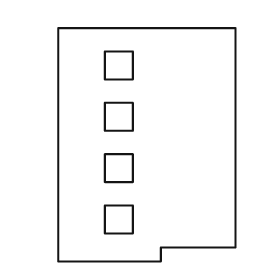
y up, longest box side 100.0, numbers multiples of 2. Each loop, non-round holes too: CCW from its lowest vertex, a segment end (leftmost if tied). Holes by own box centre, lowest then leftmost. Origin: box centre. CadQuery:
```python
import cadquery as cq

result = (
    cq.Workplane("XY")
    .moveTo(-38.0, -50.0)
    .lineTo(6.0, -50.0)
    .lineTo(6.0, -44.0)
    .lineTo(38.0, -44.0)
    .lineTo(38.0, 50.0)
    .lineTo(-38.0, 50.0)
    .close()
    .moveTo(-18.0, -38.0)
    .lineTo(-6.0, -38.0)
    .lineTo(-6.0, -26.0)
    .lineTo(-18.0, -26.0)
    .close()
    .moveTo(-18.0, -16.0)
    .lineTo(-6.0, -16.0)
    .lineTo(-6.0, -4.0)
    .lineTo(-18.0, -4.0)
    .close()
    .moveTo(-18.0, 6.0)
    .lineTo(-6.0, 6.0)
    .lineTo(-6.0, 18.0)
    .lineTo(-18.0, 18.0)
    .close()
    .moveTo(-18.0, 28.0)
    .lineTo(-6.0, 28.0)
    .lineTo(-6.0, 40.0)
    .lineTo(-18.0, 40.0)
    .close()
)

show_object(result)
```